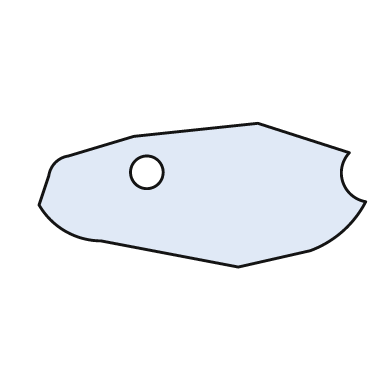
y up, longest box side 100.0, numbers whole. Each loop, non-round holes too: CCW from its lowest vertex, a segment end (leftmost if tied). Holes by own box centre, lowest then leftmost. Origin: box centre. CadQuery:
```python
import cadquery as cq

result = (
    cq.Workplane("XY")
    .moveTo(11.0, -22.0)
    .lineTo(33.0, -17.0)
    .threePointArc((43.0, -11.0), (50.0, -2.0))
    .threePointArc((43.0, 4.0), (45.0, 13.0))
    .lineTo(17.0, 22.0)
    .lineTo(-21.0, 18.0)
    .lineTo(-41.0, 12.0)
    .threePointArc((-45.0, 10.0), (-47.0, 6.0))
    .lineTo(-50.0, -3.0)
    .threePointArc((-42.0, -11.0), (-31.0, -14.0))
    .close()
    .moveTo(-17.0, 7.0)
    .circle(5.0)
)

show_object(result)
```